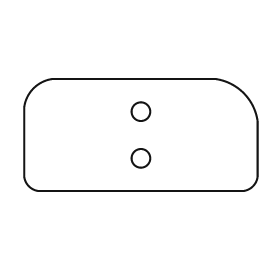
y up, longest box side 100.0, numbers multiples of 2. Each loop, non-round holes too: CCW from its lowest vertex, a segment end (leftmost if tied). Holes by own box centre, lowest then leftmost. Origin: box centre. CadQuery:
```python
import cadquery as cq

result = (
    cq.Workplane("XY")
    .moveTo(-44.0, -24.0)
    .lineTo(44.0, -24.0)
    .threePointArc((48.0, -22.0), (50.0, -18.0))
    .lineTo(50.0, 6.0)
    .threePointArc((44.0, 18.0), (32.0, 24.0))
    .lineTo(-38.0, 24.0)
    .threePointArc((-46.0, 20.0), (-50.0, 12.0))
    .lineTo(-50.0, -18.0)
    .threePointArc((-48.0, -22.0), (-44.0, -24.0))
    .close()
    .moveTo(0.0, -10.0)
    .circle(4.0)
    .moveTo(0.0, 10.0)
    .circle(4.0)
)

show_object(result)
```